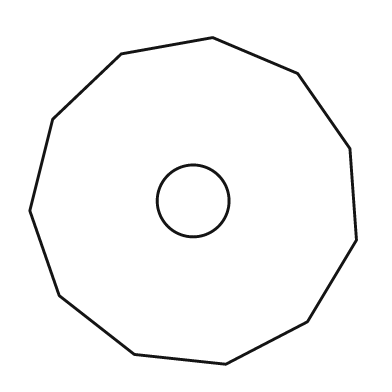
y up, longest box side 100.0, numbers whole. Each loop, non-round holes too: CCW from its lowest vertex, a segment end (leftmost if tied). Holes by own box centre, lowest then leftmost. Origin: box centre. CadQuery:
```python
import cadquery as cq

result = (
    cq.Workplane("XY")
    .moveTo(10.0, -50.0)
    .lineTo(35.0, -37.0)
    .lineTo(50.0, -12.0)
    .lineTo(48.0, 16.0)
    .lineTo(32.0, 39.0)
    .lineTo(6.0, 50.0)
    .lineTo(-22.0, 45.0)
    .lineTo(-43.0, 25.0)
    .lineTo(-50.0, -3.0)
    .lineTo(-41.0, -29.0)
    .lineTo(-18.0, -47.0)
    .close()
    .moveTo(0.0, 0.0)
    .circle(11.0)
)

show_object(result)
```